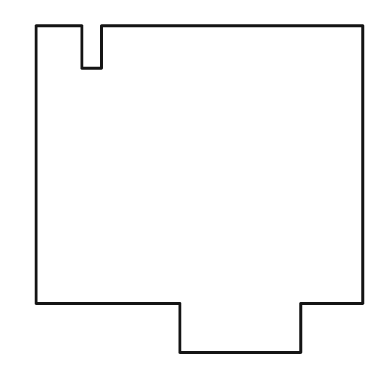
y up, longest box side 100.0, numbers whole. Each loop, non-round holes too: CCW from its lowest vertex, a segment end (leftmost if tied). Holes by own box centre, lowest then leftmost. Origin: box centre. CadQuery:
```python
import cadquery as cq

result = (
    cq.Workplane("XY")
    .moveTo(-6.0, -50.0)
    .lineTo(31.0, -50.0)
    .lineTo(31.0, -35.0)
    .lineTo(50.0, -35.0)
    .lineTo(50.0, 50.0)
    .lineTo(-30.0, 50.0)
    .lineTo(-30.0, 37.0)
    .lineTo(-36.0, 37.0)
    .lineTo(-36.0, 50.0)
    .lineTo(-50.0, 50.0)
    .lineTo(-50.0, -35.0)
    .lineTo(-6.0, -35.0)
    .close()
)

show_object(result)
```